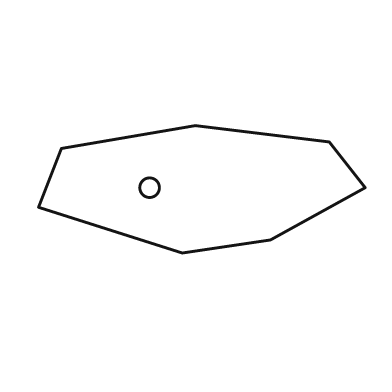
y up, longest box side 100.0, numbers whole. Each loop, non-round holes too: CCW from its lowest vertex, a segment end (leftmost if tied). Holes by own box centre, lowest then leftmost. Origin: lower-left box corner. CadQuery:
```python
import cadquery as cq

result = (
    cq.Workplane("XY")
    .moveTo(44.0, 0.0)
    .lineTo(71.0, 4.0)
    .lineTo(100.0, 20.0)
    .lineTo(89.0, 34.0)
    .lineTo(48.0, 39.0)
    .lineTo(7.0, 32.0)
    .lineTo(0.0, 14.0)
    .close()
    .moveTo(34.0, 20.0)
    .circle(3.0)
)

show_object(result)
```